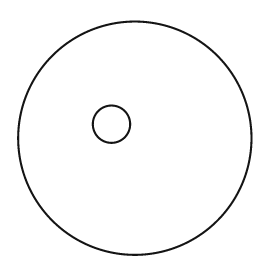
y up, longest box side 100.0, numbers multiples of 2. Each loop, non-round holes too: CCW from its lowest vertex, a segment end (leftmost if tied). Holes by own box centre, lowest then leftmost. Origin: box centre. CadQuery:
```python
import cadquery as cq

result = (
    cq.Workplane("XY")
    .moveTo(0.0, 0.0)
    .circle(50.0)
    .moveTo(-10.0, 6.0)
    .circle(8.0)
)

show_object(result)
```